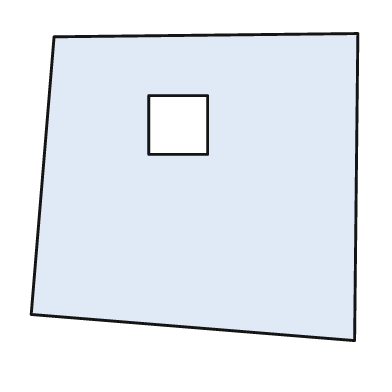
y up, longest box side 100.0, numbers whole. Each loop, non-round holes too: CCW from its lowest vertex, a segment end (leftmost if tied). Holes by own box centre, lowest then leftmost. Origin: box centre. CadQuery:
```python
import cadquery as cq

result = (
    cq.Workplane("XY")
    .moveTo(49.0, -47.0)
    .lineTo(50.0, 47.0)
    .lineTo(-43.0, 46.0)
    .lineTo(-50.0, -39.0)
    .close()
    .moveTo(-14.0, 10.0)
    .lineTo(4.0, 10.0)
    .lineTo(4.0, 28.0)
    .lineTo(-14.0, 28.0)
    .close()
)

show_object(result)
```